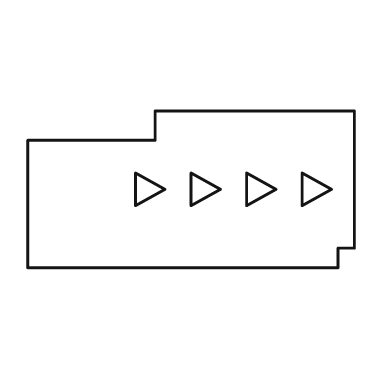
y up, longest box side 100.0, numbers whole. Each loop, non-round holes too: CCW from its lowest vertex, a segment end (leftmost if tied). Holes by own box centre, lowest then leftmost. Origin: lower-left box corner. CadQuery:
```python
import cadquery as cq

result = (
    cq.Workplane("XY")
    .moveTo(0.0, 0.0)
    .lineTo(95.0, 0.0)
    .lineTo(95.0, 6.0)
    .lineTo(100.0, 6.0)
    .lineTo(100.0, 48.0)
    .lineTo(39.0, 48.0)
    .lineTo(39.0, 39.0)
    .lineTo(0.0, 39.0)
    .close()
    .moveTo(33.0, 19.0)
    .lineTo(42.0, 24.0)
    .lineTo(33.0, 29.0)
    .close()
    .moveTo(50.0, 19.0)
    .lineTo(59.0, 24.0)
    .lineTo(50.0, 29.0)
    .close()
    .moveTo(67.0, 19.0)
    .lineTo(76.0, 24.0)
    .lineTo(67.0, 29.0)
    .close()
    .moveTo(84.0, 19.0)
    .lineTo(93.0, 24.0)
    .lineTo(84.0, 29.0)
    .close()
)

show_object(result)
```